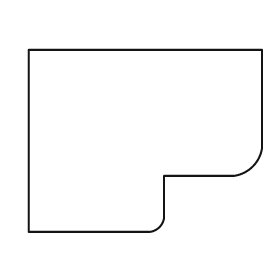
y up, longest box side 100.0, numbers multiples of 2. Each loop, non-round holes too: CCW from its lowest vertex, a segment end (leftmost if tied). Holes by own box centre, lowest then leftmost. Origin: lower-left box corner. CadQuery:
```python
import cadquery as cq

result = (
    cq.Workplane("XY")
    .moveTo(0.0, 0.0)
    .lineTo(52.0, 0.0)
    .threePointArc((56.0, 2.0), (58.0, 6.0))
    .lineTo(58.0, 24.0)
    .lineTo(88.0, 24.0)
    .threePointArc((96.0, 28.0), (100.0, 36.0))
    .lineTo(100.0, 78.0)
    .lineTo(0.0, 78.0)
    .close()
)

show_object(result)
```